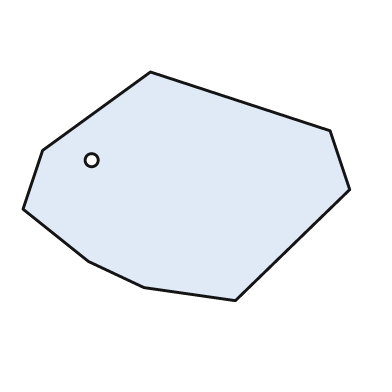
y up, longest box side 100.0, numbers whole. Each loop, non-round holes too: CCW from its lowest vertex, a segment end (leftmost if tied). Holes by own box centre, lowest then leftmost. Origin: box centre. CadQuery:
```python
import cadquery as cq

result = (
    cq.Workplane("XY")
    .moveTo(15.0, -35.0)
    .lineTo(50.0, -1.0)
    .lineTo(44.0, 17.0)
    .lineTo(-11.0, 35.0)
    .lineTo(-44.0, 11.0)
    .lineTo(-50.0, -7.0)
    .lineTo(-30.0, -23.0)
    .lineTo(-13.0, -31.0)
    .close()
    .moveTo(-29.0, 8.0)
    .circle(2.0)
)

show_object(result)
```